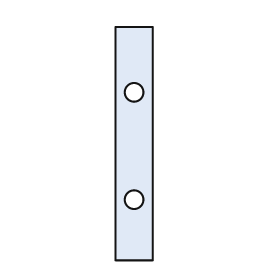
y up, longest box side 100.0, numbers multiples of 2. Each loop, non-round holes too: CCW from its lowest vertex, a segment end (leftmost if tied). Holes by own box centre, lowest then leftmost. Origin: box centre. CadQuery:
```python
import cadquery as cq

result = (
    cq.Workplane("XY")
    .moveTo(-8.0, -50.0)
    .lineTo(8.0, -50.0)
    .lineTo(8.0, 50.0)
    .lineTo(-8.0, 50.0)
    .close()
    .moveTo(0.0, -24.0)
    .circle(4.0)
    .moveTo(0.0, 22.0)
    .circle(4.0)
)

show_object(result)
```